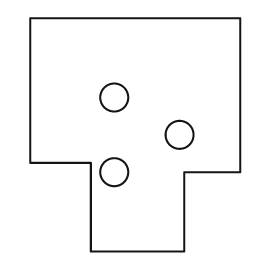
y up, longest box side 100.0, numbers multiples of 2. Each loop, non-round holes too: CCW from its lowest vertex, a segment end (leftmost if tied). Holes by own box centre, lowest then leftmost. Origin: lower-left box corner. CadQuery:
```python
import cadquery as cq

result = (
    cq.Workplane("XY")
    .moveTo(26.0, 0.0)
    .lineTo(66.0, 0.0)
    .lineTo(66.0, 34.0)
    .lineTo(90.0, 34.0)
    .lineTo(90.0, 100.0)
    .lineTo(0.0, 100.0)
    .lineTo(0.0, 38.0)
    .lineTo(26.0, 38.0)
    .close()
    .moveTo(36.0, 34.0)
    .circle(6.0)
    .moveTo(64.0, 50.0)
    .circle(6.0)
    .moveTo(36.0, 66.0)
    .circle(6.0)
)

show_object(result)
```